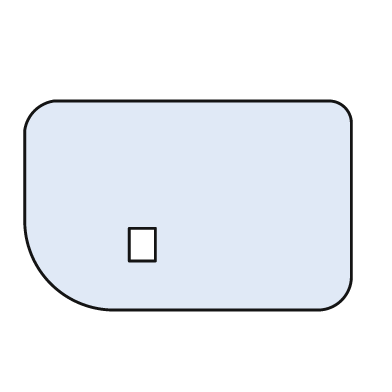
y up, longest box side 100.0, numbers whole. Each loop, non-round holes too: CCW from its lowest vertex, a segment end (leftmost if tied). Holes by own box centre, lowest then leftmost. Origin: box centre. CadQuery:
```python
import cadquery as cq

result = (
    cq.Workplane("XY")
    .moveTo(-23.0, -32.0)
    .lineTo(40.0, -32.0)
    .threePointArc((47.0, -29.0), (50.0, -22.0))
    .lineTo(50.0, 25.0)
    .threePointArc((48.0, 30.0), (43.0, 32.0))
    .lineTo(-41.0, 32.0)
    .threePointArc((-47.0, 29.0), (-50.0, 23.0))
    .lineTo(-50.0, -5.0)
    .threePointArc((-42.0, -24.0), (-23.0, -32.0))
    .close()
    .moveTo(-18.0, -17.0)
    .lineTo(-10.0, -17.0)
    .lineTo(-10.0, -7.0)
    .lineTo(-18.0, -7.0)
    .close()
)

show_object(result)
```